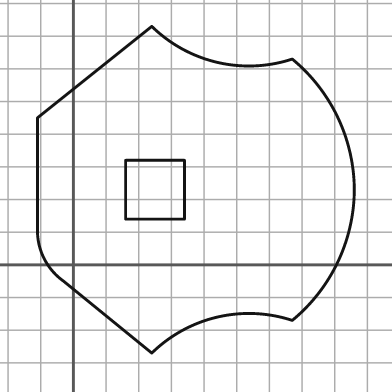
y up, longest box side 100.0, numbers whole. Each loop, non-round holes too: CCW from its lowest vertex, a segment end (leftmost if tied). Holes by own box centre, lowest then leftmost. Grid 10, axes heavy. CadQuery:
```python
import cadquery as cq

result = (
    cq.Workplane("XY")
    .moveTo(24.0, -27.0)
    .threePointArc((44.0, -16.0), (67.0, -17.0))
    .threePointArc((81.0, 1.0), (86.0, 23.0))
    .threePointArc((81.0, 45.0), (67.0, 63.0))
    .threePointArc((44.0, 62.0), (24.0, 73.0))
    .lineTo(-11.0, 45.0)
    .lineTo(-11.0, 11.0)
    .threePointArc((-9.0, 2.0), (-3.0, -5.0))
    .close()
    .moveTo(16.0, 14.0)
    .lineTo(34.0, 14.0)
    .lineTo(34.0, 32.0)
    .lineTo(16.0, 32.0)
    .close()
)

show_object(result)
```